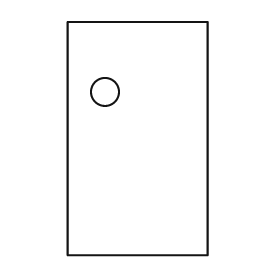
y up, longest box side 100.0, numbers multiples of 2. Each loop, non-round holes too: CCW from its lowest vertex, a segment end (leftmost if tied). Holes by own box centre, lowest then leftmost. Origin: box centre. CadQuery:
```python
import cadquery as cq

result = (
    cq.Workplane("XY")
    .moveTo(-30.0, -50.0)
    .lineTo(30.0, -50.0)
    .lineTo(30.0, 50.0)
    .lineTo(-30.0, 50.0)
    .close()
    .moveTo(-14.0, 20.0)
    .circle(6.0)
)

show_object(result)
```